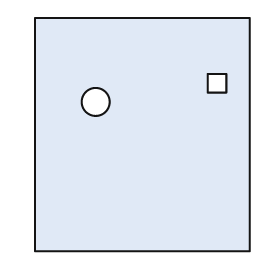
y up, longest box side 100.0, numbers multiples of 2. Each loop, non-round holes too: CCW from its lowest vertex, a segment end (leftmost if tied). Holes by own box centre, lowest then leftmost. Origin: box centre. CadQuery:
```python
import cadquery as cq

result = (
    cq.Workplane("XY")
    .moveTo(-46.0, -50.0)
    .lineTo(46.0, -50.0)
    .lineTo(46.0, 50.0)
    .lineTo(-46.0, 50.0)
    .close()
    .moveTo(-20.0, 14.0)
    .circle(6.0)
    .moveTo(28.0, 18.0)
    .lineTo(36.0, 18.0)
    .lineTo(36.0, 26.0)
    .lineTo(28.0, 26.0)
    .close()
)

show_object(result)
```